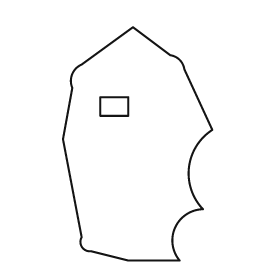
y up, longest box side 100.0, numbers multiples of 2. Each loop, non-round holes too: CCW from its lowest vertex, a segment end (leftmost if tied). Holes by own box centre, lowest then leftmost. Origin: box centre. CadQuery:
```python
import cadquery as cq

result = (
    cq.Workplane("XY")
    .moveTo(-4.0, -50.0)
    .lineTo(18.0, -50.0)
    .threePointArc((16.0, -36.0), (28.0, -28.0))
    .threePointArc((22.0, -10.0), (32.0, 6.0))
    .lineTo(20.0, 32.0)
    .threePointArc((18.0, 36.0), (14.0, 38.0))
    .lineTo(-2.0, 50.0)
    .lineTo(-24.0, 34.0)
    .threePointArc((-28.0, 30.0), (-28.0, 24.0))
    .lineTo(-32.0, 2.0)
    .lineTo(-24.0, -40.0)
    .threePointArc((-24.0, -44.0), (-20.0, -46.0))
    .close()
    .moveTo(-16.0, 12.0)
    .lineTo(-4.0, 12.0)
    .lineTo(-4.0, 20.0)
    .lineTo(-16.0, 20.0)
    .close()
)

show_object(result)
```